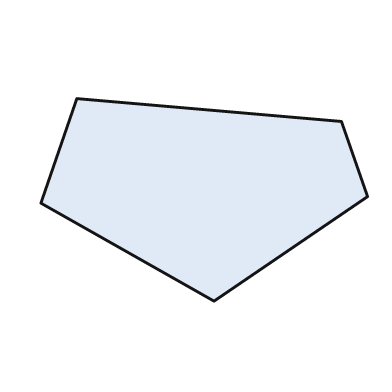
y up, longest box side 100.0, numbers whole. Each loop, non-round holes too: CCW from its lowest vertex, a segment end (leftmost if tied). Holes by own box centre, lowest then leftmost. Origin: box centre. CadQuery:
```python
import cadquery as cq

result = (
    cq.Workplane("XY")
    .moveTo(3.0, -31.0)
    .lineTo(50.0, 1.0)
    .lineTo(42.0, 24.0)
    .lineTo(-39.0, 31.0)
    .lineTo(-50.0, -1.0)
    .close()
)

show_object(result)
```